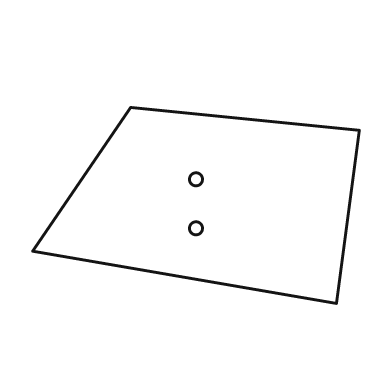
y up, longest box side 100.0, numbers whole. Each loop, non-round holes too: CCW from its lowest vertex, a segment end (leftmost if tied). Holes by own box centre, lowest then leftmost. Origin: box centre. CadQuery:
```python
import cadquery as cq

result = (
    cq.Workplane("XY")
    .moveTo(43.0, -30.0)
    .lineTo(50.0, 23.0)
    .lineTo(-20.0, 30.0)
    .lineTo(-50.0, -14.0)
    .close()
    .moveTo(0.0, -7.0)
    .circle(2.0)
    .moveTo(0.0, 8.0)
    .circle(2.0)
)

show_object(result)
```